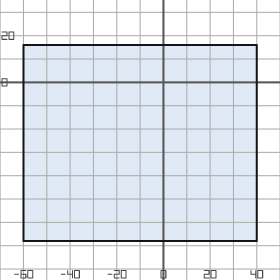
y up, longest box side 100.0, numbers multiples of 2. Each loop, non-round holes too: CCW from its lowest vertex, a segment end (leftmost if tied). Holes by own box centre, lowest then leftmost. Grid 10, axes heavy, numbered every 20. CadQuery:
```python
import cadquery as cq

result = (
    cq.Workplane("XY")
    .moveTo(-60.0, -68.0)
    .lineTo(40.0, -68.0)
    .lineTo(40.0, 16.0)
    .lineTo(-60.0, 16.0)
    .close()
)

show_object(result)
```